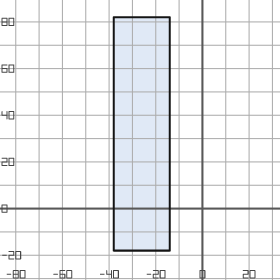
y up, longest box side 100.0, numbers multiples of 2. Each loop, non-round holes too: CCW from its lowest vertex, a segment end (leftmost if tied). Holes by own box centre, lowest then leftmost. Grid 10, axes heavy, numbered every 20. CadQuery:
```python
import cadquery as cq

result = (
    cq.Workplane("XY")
    .moveTo(-38.0, -18.0)
    .lineTo(-14.0, -18.0)
    .lineTo(-14.0, 82.0)
    .lineTo(-38.0, 82.0)
    .close()
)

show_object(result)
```